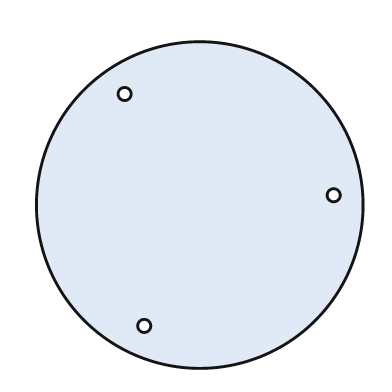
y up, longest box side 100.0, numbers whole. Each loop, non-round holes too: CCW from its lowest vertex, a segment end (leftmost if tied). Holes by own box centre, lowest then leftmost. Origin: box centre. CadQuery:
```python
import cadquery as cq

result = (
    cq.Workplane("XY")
    .moveTo(0.0, 0.0)
    .circle(50.0)
    .moveTo(-17.0, -37.0)
    .circle(2.0)
    .moveTo(41.0, 3.0)
    .circle(2.0)
    .moveTo(-23.0, 34.0)
    .circle(2.0)
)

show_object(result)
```